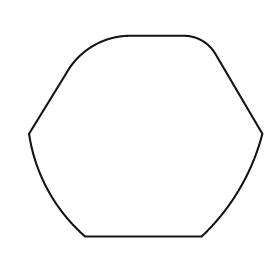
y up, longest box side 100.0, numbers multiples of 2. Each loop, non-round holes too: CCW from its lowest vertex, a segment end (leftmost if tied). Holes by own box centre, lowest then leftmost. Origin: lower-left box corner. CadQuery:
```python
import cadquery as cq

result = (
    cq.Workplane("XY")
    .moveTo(24.0, 0.0)
    .lineTo(74.0, 0.0)
    .threePointArc((90.0, 20.0), (100.0, 44.0))
    .lineTo(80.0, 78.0)
    .threePointArc((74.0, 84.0), (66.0, 86.0))
    .lineTo(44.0, 86.0)
    .threePointArc((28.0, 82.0), (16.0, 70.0))
    .lineTo(0.0, 44.0)
    .threePointArc((8.0, 20.0), (24.0, 0.0))
    .close()
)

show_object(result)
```